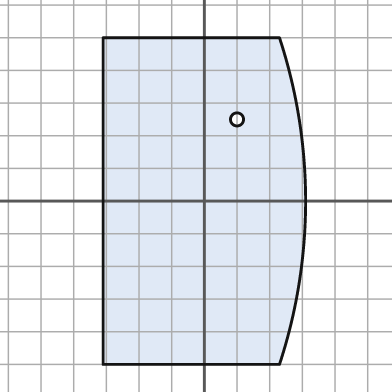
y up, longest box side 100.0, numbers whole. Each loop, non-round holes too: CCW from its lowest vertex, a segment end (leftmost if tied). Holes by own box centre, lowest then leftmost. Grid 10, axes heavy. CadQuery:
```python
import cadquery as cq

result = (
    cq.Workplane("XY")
    .moveTo(-31.0, -50.0)
    .lineTo(23.0, -50.0)
    .threePointArc((31.0, 0.0), (23.0, 50.0))
    .lineTo(-31.0, 50.0)
    .close()
    .moveTo(10.0, 25.0)
    .circle(2.0)
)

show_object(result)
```